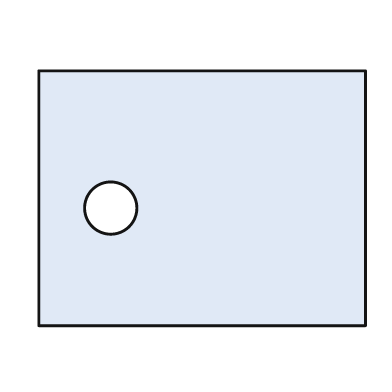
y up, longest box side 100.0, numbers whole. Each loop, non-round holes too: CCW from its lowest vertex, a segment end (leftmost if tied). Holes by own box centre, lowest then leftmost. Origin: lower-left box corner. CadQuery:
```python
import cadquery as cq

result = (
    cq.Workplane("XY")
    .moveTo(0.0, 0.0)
    .lineTo(100.0, 0.0)
    .lineTo(100.0, 78.0)
    .lineTo(0.0, 78.0)
    .close()
    .moveTo(22.0, 36.0)
    .circle(8.0)
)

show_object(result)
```